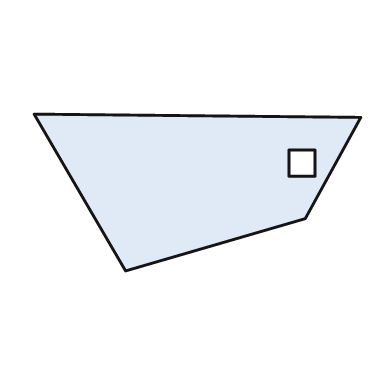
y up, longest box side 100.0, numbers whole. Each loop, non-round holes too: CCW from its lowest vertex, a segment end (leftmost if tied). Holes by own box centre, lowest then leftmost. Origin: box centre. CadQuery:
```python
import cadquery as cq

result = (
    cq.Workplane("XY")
    .moveTo(-22.0, -24.0)
    .lineTo(33.0, -8.0)
    .lineTo(50.0, 23.0)
    .lineTo(-50.0, 24.0)
    .close()
    .moveTo(28.0, 5.0)
    .lineTo(36.0, 5.0)
    .lineTo(36.0, 13.0)
    .lineTo(28.0, 13.0)
    .close()
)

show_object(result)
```